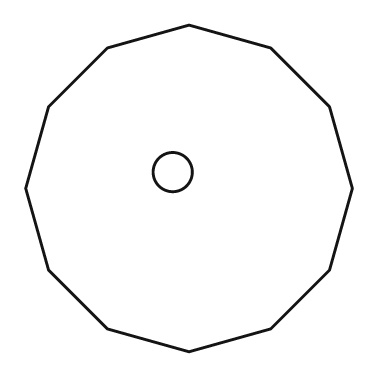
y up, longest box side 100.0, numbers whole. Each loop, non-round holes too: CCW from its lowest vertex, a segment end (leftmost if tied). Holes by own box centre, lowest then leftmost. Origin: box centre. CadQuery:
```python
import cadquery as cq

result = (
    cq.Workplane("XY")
    .moveTo(0.0, -50.0)
    .lineTo(25.0, -43.0)
    .lineTo(43.0, -25.0)
    .lineTo(50.0, 0.0)
    .lineTo(43.0, 25.0)
    .lineTo(25.0, 43.0)
    .lineTo(0.0, 50.0)
    .lineTo(-25.0, 43.0)
    .lineTo(-43.0, 25.0)
    .lineTo(-50.0, 0.0)
    .lineTo(-43.0, -25.0)
    .lineTo(-25.0, -43.0)
    .close()
    .moveTo(-5.0, 5.0)
    .circle(6.0)
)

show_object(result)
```